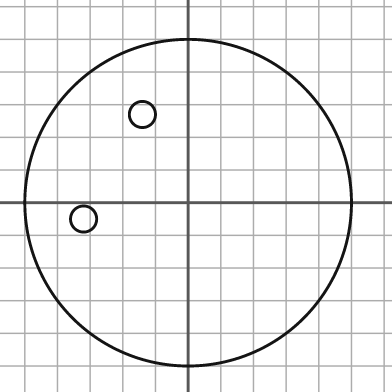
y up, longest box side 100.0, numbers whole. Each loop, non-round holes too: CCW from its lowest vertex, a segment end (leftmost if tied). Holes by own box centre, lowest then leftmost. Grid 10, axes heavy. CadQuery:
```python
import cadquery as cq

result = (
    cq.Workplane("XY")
    .moveTo(0.0, 0.0)
    .circle(50.0)
    .moveTo(-32.0, -5.0)
    .circle(4.0)
    .moveTo(-14.0, 27.0)
    .circle(4.0)
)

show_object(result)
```